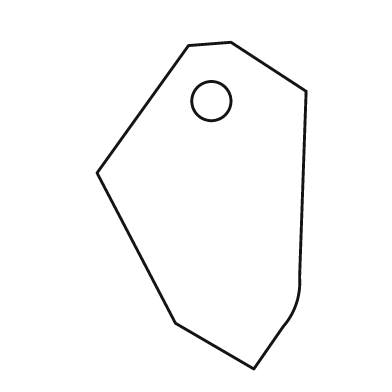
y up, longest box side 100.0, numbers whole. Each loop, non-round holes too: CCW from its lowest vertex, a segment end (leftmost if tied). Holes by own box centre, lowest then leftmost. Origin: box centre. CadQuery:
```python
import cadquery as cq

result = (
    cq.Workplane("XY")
    .moveTo(16.0, -50.0)
    .lineTo(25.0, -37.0)
    .threePointArc((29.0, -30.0), (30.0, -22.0))
    .lineTo(32.0, 35.0)
    .lineTo(9.0, 50.0)
    .lineTo(-4.0, 49.0)
    .lineTo(-32.0, 10.0)
    .lineTo(-8.0, -36.0)
    .close()
    .moveTo(3.0, 32.0)
    .circle(6.0)
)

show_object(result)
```